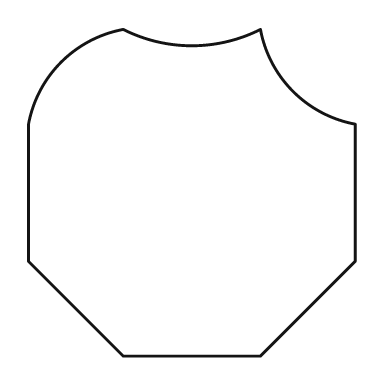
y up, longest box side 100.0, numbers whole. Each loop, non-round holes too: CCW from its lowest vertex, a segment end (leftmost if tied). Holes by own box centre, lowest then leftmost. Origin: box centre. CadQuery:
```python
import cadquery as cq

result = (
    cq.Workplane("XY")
    .moveTo(-21.0, -50.0)
    .lineTo(21.0, -50.0)
    .lineTo(50.0, -21.0)
    .lineTo(50.0, 21.0)
    .threePointArc((31.0, 31.0), (21.0, 50.0))
    .threePointArc((0.0, 45.0), (-21.0, 50.0))
    .threePointArc((-40.0, 40.0), (-50.0, 21.0))
    .lineTo(-50.0, -21.0)
    .close()
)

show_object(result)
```